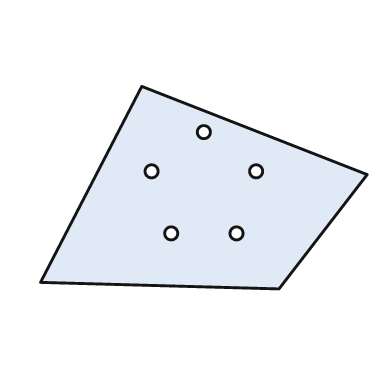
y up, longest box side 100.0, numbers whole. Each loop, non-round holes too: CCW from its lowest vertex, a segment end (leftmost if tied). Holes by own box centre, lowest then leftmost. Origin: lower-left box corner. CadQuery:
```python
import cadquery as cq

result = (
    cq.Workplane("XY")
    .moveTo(73.0, 0.0)
    .lineTo(100.0, 35.0)
    .lineTo(31.0, 62.0)
    .lineTo(0.0, 2.0)
    .close()
    .moveTo(40.0, 17.0)
    .circle(2.0)
    .moveTo(60.0, 17.0)
    .circle(2.0)
    .moveTo(34.0, 36.0)
    .circle(2.0)
    .moveTo(66.0, 36.0)
    .circle(2.0)
    .moveTo(50.0, 48.0)
    .circle(2.0)
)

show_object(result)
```